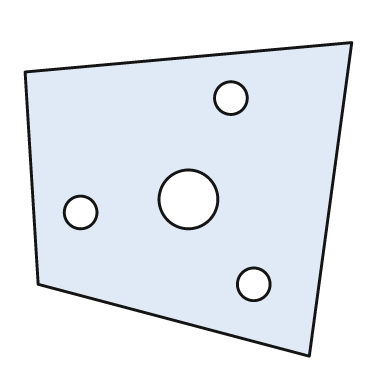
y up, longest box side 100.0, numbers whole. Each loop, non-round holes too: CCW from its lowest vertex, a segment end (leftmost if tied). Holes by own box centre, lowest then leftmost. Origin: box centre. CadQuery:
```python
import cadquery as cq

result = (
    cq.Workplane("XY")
    .moveTo(37.0, -48.0)
    .lineTo(50.0, 48.0)
    .lineTo(-50.0, 39.0)
    .lineTo(-46.0, -26.0)
    .close()
    .moveTo(20.0, -26.0)
    .circle(5.0)
    .moveTo(-33.0, -4.0)
    .circle(5.0)
    .moveTo(0.0, 0.0)
    .circle(9.0)
    .moveTo(13.0, 31.0)
    .circle(5.0)
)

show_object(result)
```